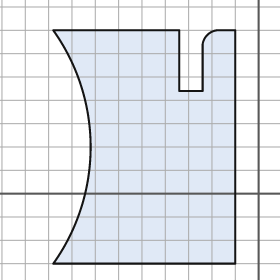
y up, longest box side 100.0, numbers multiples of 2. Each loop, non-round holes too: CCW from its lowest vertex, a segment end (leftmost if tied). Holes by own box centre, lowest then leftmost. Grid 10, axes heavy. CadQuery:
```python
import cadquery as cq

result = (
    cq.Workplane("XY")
    .moveTo(-88.0, -30.0)
    .lineTo(-10.0, -30.0)
    .lineTo(-10.0, 70.0)
    .lineTo(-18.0, 70.0)
    .threePointArc((-22.0, 68.0), (-24.0, 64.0))
    .lineTo(-24.0, 44.0)
    .lineTo(-34.0, 44.0)
    .lineTo(-34.0, 70.0)
    .lineTo(-88.0, 70.0)
    .threePointArc((-72.0, 20.0), (-88.0, -30.0))
    .close()
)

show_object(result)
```